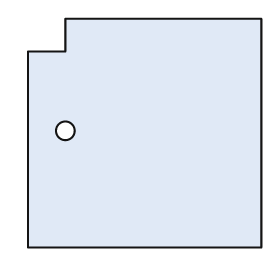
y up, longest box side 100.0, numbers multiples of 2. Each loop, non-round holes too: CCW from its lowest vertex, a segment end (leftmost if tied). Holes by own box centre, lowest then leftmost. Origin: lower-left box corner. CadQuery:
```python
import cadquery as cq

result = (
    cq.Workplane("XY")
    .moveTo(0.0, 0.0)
    .lineTo(100.0, 0.0)
    .lineTo(100.0, 98.0)
    .lineTo(16.0, 98.0)
    .lineTo(16.0, 84.0)
    .lineTo(0.0, 84.0)
    .close()
    .moveTo(16.0, 50.0)
    .circle(4.0)
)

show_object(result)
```